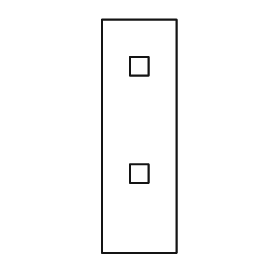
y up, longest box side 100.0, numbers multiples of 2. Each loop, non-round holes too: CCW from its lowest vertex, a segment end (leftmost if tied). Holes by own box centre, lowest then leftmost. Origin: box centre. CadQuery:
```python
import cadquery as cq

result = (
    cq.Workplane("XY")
    .moveTo(-16.0, -50.0)
    .lineTo(16.0, -50.0)
    .lineTo(16.0, 50.0)
    .lineTo(-16.0, 50.0)
    .close()
    .moveTo(-4.0, -20.0)
    .lineTo(4.0, -20.0)
    .lineTo(4.0, -12.0)
    .lineTo(-4.0, -12.0)
    .close()
    .moveTo(-4.0, 26.0)
    .lineTo(4.0, 26.0)
    .lineTo(4.0, 34.0)
    .lineTo(-4.0, 34.0)
    .close()
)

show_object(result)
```